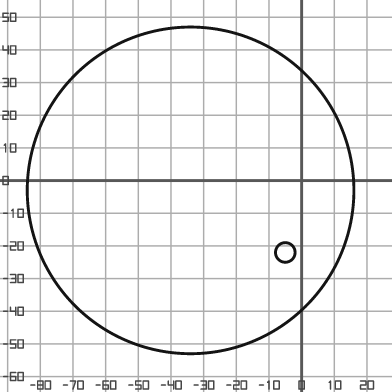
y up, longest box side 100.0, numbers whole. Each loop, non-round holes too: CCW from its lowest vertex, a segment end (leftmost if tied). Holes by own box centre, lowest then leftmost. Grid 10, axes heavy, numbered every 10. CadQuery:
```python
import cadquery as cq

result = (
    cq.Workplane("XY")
    .moveTo(-34.0, -3.0)
    .circle(50.0)
    .moveTo(-5.0, -22.0)
    .circle(3.0)
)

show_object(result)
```